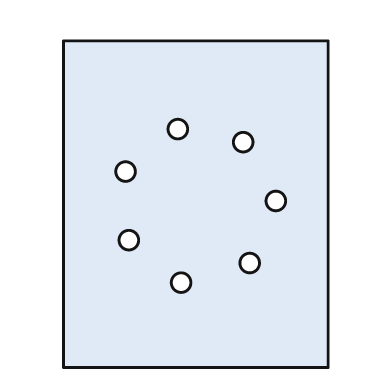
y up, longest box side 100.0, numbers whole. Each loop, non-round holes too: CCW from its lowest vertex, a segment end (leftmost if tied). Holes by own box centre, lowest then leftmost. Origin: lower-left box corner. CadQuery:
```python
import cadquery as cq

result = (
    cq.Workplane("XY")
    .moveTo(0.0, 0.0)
    .lineTo(81.0, 0.0)
    .lineTo(81.0, 100.0)
    .lineTo(0.0, 100.0)
    .close()
    .moveTo(36.0, 26.0)
    .circle(3.0)
    .moveTo(57.0, 32.0)
    .circle(3.0)
    .moveTo(20.0, 39.0)
    .circle(3.0)
    .moveTo(65.0, 51.0)
    .circle(3.0)
    .moveTo(19.0, 60.0)
    .circle(3.0)
    .moveTo(55.0, 69.0)
    .circle(3.0)
    .moveTo(35.0, 73.0)
    .circle(3.0)
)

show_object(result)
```